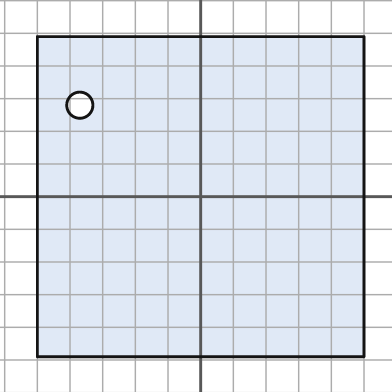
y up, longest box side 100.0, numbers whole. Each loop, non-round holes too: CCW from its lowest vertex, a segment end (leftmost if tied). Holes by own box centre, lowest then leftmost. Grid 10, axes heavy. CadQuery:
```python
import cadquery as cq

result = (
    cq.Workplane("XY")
    .moveTo(-50.0, -49.0)
    .lineTo(50.0, -49.0)
    .lineTo(50.0, 49.0)
    .lineTo(-50.0, 49.0)
    .close()
    .moveTo(-37.0, 28.0)
    .circle(4.0)
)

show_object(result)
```